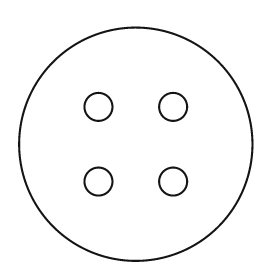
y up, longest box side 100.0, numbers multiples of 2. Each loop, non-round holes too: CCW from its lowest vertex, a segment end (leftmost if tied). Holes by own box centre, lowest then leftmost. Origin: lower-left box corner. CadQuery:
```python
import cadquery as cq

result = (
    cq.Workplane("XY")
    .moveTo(50.0, 50.0)
    .circle(50.0)
    .moveTo(34.0, 34.0)
    .circle(6.0)
    .moveTo(66.0, 34.0)
    .circle(6.0)
    .moveTo(34.0, 66.0)
    .circle(6.0)
    .moveTo(66.0, 66.0)
    .circle(6.0)
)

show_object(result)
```